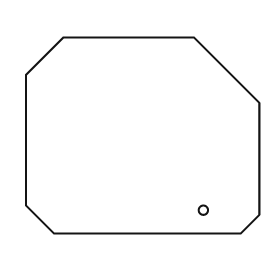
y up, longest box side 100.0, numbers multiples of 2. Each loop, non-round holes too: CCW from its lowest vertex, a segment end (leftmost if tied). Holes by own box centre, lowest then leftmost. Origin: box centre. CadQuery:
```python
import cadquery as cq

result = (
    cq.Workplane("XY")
    .moveTo(-38.0, -42.0)
    .lineTo(42.0, -42.0)
    .lineTo(50.0, -34.0)
    .lineTo(50.0, 14.0)
    .lineTo(22.0, 42.0)
    .lineTo(-34.0, 42.0)
    .lineTo(-50.0, 26.0)
    .lineTo(-50.0, -30.0)
    .close()
    .moveTo(26.0, -32.0)
    .circle(2.0)
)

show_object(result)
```